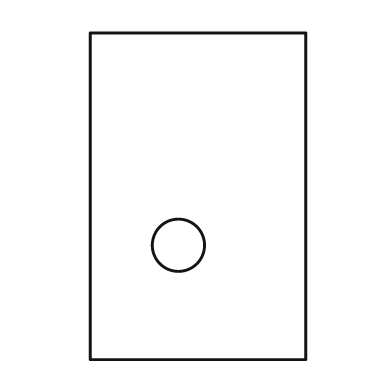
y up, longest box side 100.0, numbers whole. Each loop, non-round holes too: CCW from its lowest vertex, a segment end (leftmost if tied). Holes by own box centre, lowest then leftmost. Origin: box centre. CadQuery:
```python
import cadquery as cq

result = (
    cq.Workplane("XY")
    .moveTo(-33.0, -50.0)
    .lineTo(33.0, -50.0)
    .lineTo(33.0, 50.0)
    .lineTo(-33.0, 50.0)
    .close()
    .moveTo(-6.0, -15.0)
    .circle(8.0)
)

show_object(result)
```